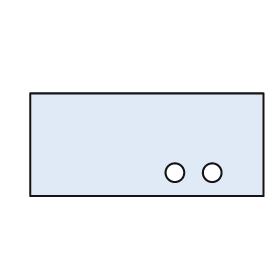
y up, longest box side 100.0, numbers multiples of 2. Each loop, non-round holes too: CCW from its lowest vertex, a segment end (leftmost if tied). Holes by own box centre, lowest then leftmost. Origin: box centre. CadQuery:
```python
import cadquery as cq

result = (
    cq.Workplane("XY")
    .moveTo(-50.0, -22.0)
    .lineTo(50.0, -22.0)
    .lineTo(50.0, 22.0)
    .lineTo(-50.0, 22.0)
    .close()
    .moveTo(12.0, -12.0)
    .circle(4.0)
    .moveTo(28.0, -12.0)
    .circle(4.0)
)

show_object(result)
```